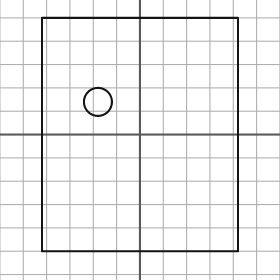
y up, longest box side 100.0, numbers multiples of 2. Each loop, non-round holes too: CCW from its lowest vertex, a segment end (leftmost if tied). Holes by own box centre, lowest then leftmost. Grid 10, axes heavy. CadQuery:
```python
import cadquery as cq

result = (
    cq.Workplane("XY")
    .moveTo(-42.0, -50.0)
    .lineTo(42.0, -50.0)
    .lineTo(42.0, 50.0)
    .lineTo(-42.0, 50.0)
    .close()
    .moveTo(-18.0, 14.0)
    .circle(6.0)
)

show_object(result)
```